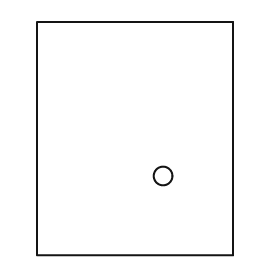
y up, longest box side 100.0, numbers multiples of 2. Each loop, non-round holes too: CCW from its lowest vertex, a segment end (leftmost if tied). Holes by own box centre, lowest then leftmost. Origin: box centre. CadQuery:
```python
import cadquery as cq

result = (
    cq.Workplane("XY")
    .moveTo(-42.0, -50.0)
    .lineTo(42.0, -50.0)
    .lineTo(42.0, 50.0)
    .lineTo(-42.0, 50.0)
    .close()
    .moveTo(12.0, -16.0)
    .circle(4.0)
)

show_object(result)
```